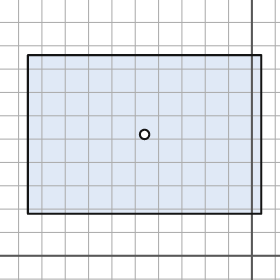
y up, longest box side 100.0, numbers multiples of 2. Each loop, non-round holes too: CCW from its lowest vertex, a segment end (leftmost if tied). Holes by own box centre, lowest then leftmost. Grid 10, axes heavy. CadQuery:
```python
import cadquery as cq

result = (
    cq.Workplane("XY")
    .moveTo(-96.0, 18.0)
    .lineTo(4.0, 18.0)
    .lineTo(4.0, 86.0)
    .lineTo(-96.0, 86.0)
    .close()
    .moveTo(-46.0, 52.0)
    .circle(2.0)
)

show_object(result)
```